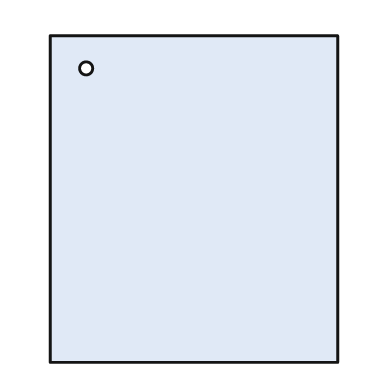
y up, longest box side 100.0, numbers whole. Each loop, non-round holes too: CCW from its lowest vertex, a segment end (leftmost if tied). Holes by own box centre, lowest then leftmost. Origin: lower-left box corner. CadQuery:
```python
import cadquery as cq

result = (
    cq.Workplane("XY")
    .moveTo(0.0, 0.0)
    .lineTo(88.0, 0.0)
    .lineTo(88.0, 100.0)
    .lineTo(0.0, 100.0)
    .close()
    .moveTo(11.0, 90.0)
    .circle(2.0)
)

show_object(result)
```